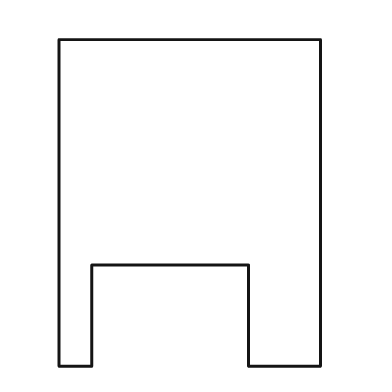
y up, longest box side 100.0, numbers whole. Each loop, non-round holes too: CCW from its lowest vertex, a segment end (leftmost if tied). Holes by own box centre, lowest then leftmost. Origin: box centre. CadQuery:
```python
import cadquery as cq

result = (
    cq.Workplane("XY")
    .moveTo(-40.0, -50.0)
    .lineTo(-30.0, -50.0)
    .lineTo(-30.0, -19.0)
    .lineTo(18.0, -19.0)
    .lineTo(18.0, -50.0)
    .lineTo(40.0, -50.0)
    .lineTo(40.0, 50.0)
    .lineTo(-40.0, 50.0)
    .close()
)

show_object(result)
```